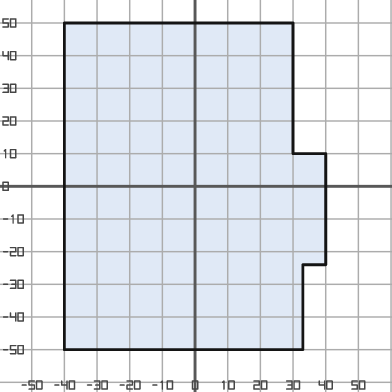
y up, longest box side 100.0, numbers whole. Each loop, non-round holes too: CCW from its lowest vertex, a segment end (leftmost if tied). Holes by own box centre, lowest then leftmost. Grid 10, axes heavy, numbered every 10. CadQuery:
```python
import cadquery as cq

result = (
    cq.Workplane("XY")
    .moveTo(-40.0, -50.0)
    .lineTo(33.0, -50.0)
    .lineTo(33.0, -24.0)
    .lineTo(40.0, -24.0)
    .lineTo(40.0, 10.0)
    .lineTo(30.0, 10.0)
    .lineTo(30.0, 50.0)
    .lineTo(-40.0, 50.0)
    .close()
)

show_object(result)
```